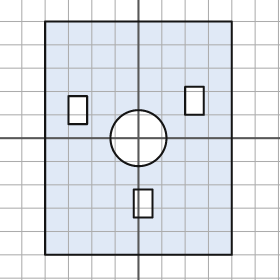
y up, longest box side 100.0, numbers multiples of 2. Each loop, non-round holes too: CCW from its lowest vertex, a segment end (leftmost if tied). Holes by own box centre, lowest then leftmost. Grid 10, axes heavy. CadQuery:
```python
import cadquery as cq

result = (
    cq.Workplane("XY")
    .moveTo(-40.0, -50.0)
    .lineTo(40.0, -50.0)
    .lineTo(40.0, 50.0)
    .lineTo(-40.0, 50.0)
    .close()
    .moveTo(-2.0, -34.0)
    .lineTo(6.0, -34.0)
    .lineTo(6.0, -22.0)
    .lineTo(-2.0, -22.0)
    .close()
    .moveTo(0.0, 0.0)
    .circle(12.0)
    .moveTo(-30.0, 6.0)
    .lineTo(-22.0, 6.0)
    .lineTo(-22.0, 18.0)
    .lineTo(-30.0, 18.0)
    .close()
    .moveTo(20.0, 10.0)
    .lineTo(28.0, 10.0)
    .lineTo(28.0, 22.0)
    .lineTo(20.0, 22.0)
    .close()
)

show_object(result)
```